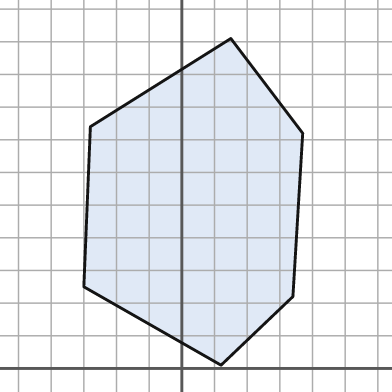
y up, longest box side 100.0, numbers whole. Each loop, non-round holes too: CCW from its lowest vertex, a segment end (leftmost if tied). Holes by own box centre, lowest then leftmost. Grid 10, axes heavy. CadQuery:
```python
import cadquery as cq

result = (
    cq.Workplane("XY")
    .moveTo(12.0, 1.0)
    .lineTo(34.0, 22.0)
    .lineTo(37.0, 72.0)
    .lineTo(15.0, 101.0)
    .lineTo(-28.0, 74.0)
    .lineTo(-30.0, 25.0)
    .close()
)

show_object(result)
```